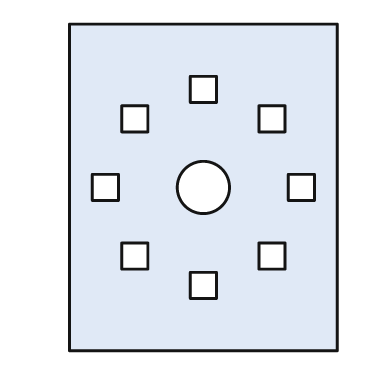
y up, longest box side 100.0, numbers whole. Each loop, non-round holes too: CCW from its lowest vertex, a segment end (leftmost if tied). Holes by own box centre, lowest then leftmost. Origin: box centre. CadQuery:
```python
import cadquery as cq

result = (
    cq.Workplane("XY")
    .moveTo(-41.0, -50.0)
    .lineTo(41.0, -50.0)
    .lineTo(41.0, 50.0)
    .lineTo(-41.0, 50.0)
    .close()
    .moveTo(-4.0, -34.0)
    .lineTo(4.0, -34.0)
    .lineTo(4.0, -26.0)
    .lineTo(-4.0, -26.0)
    .close()
    .moveTo(-25.0, -25.0)
    .lineTo(-17.0, -25.0)
    .lineTo(-17.0, -17.0)
    .lineTo(-25.0, -17.0)
    .close()
    .moveTo(17.0, -25.0)
    .lineTo(25.0, -25.0)
    .lineTo(25.0, -17.0)
    .lineTo(17.0, -17.0)
    .close()
    .moveTo(-34.0, -4.0)
    .lineTo(-26.0, -4.0)
    .lineTo(-26.0, 4.0)
    .lineTo(-34.0, 4.0)
    .close()
    .moveTo(0.0, 0.0)
    .circle(8.0)
    .moveTo(26.0, -4.0)
    .lineTo(34.0, -4.0)
    .lineTo(34.0, 4.0)
    .lineTo(26.0, 4.0)
    .close()
    .moveTo(-25.0, 17.0)
    .lineTo(-17.0, 17.0)
    .lineTo(-17.0, 25.0)
    .lineTo(-25.0, 25.0)
    .close()
    .moveTo(17.0, 17.0)
    .lineTo(25.0, 17.0)
    .lineTo(25.0, 25.0)
    .lineTo(17.0, 25.0)
    .close()
    .moveTo(-4.0, 26.0)
    .lineTo(4.0, 26.0)
    .lineTo(4.0, 34.0)
    .lineTo(-4.0, 34.0)
    .close()
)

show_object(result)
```